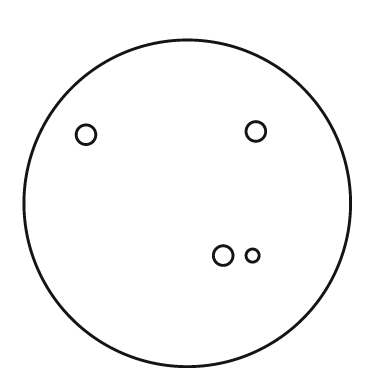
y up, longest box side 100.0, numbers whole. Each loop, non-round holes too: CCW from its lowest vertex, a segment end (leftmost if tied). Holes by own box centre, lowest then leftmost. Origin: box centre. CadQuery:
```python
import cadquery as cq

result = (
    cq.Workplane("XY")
    .moveTo(0.0, 0.0)
    .circle(50.0)
    .moveTo(11.0, -16.0)
    .circle(3.0)
    .moveTo(20.0, -16.0)
    .circle(2.0)
    .moveTo(-31.0, 21.0)
    .circle(3.0)
    .moveTo(21.0, 22.0)
    .circle(3.0)
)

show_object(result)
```